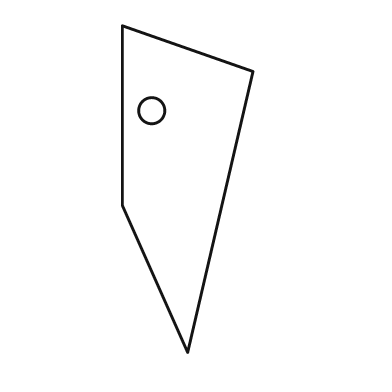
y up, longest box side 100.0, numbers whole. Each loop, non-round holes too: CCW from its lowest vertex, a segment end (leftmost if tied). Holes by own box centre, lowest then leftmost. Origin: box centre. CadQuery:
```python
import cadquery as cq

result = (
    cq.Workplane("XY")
    .moveTo(0.0, -50.0)
    .lineTo(20.0, 36.0)
    .lineTo(-20.0, 50.0)
    .lineTo(-20.0, -5.0)
    .close()
    .moveTo(-11.0, 24.0)
    .circle(4.0)
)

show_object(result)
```